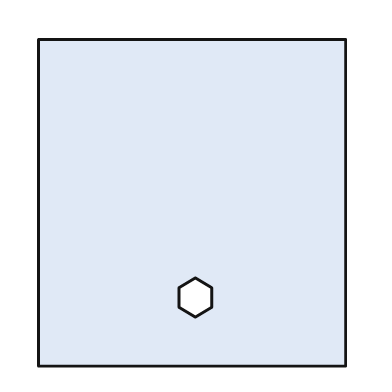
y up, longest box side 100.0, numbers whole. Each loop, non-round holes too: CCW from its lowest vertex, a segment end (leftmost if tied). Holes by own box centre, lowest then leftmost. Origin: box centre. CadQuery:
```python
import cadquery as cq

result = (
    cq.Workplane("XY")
    .moveTo(-47.0, -50.0)
    .lineTo(47.0, -50.0)
    .lineTo(47.0, 50.0)
    .lineTo(-47.0, 50.0)
    .close()
    .moveTo(1.0, -35.0)
    .lineTo(6.0, -32.0)
    .lineTo(6.0, -26.0)
    .lineTo(1.0, -23.0)
    .lineTo(-4.0, -26.0)
    .lineTo(-4.0, -32.0)
    .close()
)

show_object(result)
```